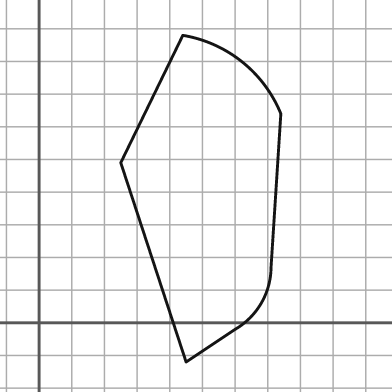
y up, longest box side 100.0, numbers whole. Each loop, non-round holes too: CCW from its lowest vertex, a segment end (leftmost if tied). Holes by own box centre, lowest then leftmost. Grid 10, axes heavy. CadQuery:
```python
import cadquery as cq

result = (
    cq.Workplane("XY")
    .moveTo(45.0, -12.0)
    .lineTo(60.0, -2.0)
    .threePointArc((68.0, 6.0), (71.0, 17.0))
    .lineTo(74.0, 64.0)
    .threePointArc((62.0, 80.0), (44.0, 88.0))
    .lineTo(25.0, 49.0)
    .close()
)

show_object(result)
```